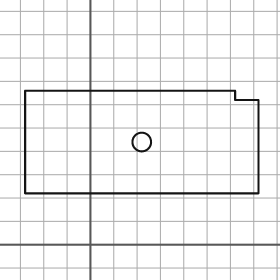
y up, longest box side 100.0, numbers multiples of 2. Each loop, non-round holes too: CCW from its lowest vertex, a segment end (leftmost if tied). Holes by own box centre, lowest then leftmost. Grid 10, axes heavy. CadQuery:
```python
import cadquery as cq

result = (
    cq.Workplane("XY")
    .moveTo(-28.0, 22.0)
    .lineTo(72.0, 22.0)
    .lineTo(72.0, 62.0)
    .lineTo(62.0, 62.0)
    .lineTo(62.0, 66.0)
    .lineTo(-28.0, 66.0)
    .close()
    .moveTo(22.0, 44.0)
    .circle(4.0)
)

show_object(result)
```